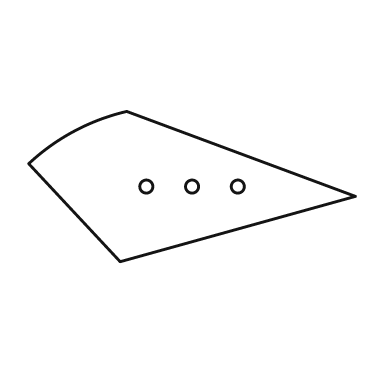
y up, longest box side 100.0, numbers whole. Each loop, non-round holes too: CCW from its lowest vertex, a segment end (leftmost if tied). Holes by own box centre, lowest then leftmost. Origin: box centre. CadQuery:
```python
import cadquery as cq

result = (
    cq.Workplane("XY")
    .moveTo(-22.0, -23.0)
    .lineTo(50.0, -3.0)
    .lineTo(-20.0, 23.0)
    .threePointArc((-36.0, 17.0), (-50.0, 7.0))
    .close()
    .moveTo(-14.0, 0.0)
    .circle(2.0)
    .moveTo(0.0, 0.0)
    .circle(2.0)
    .moveTo(14.0, 0.0)
    .circle(2.0)
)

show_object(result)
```